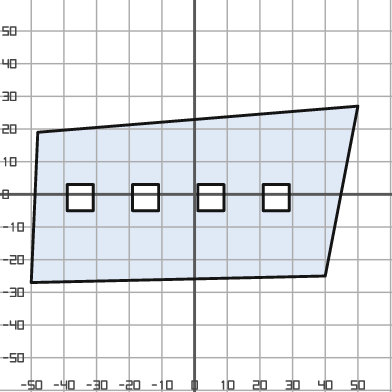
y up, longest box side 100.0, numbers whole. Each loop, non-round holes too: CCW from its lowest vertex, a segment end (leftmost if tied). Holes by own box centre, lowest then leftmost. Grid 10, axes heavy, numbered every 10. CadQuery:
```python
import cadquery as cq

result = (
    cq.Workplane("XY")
    .moveTo(-50.0, -27.0)
    .lineTo(40.0, -25.0)
    .lineTo(50.0, 27.0)
    .lineTo(-48.0, 19.0)
    .close()
    .moveTo(-39.0, -5.0)
    .lineTo(-31.0, -5.0)
    .lineTo(-31.0, 3.0)
    .lineTo(-39.0, 3.0)
    .close()
    .moveTo(-19.0, -5.0)
    .lineTo(-11.0, -5.0)
    .lineTo(-11.0, 3.0)
    .lineTo(-19.0, 3.0)
    .close()
    .moveTo(1.0, -5.0)
    .lineTo(9.0, -5.0)
    .lineTo(9.0, 3.0)
    .lineTo(1.0, 3.0)
    .close()
    .moveTo(21.0, -5.0)
    .lineTo(29.0, -5.0)
    .lineTo(29.0, 3.0)
    .lineTo(21.0, 3.0)
    .close()
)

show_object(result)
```